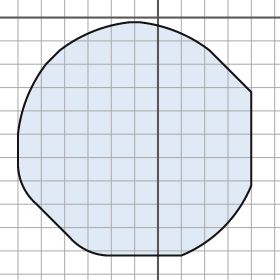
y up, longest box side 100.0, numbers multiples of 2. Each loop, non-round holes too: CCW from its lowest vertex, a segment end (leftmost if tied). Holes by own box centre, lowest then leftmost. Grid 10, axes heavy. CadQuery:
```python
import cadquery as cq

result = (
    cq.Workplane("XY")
    .moveTo(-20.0, -102.0)
    .lineTo(10.0, -102.0)
    .threePointArc((28.0, -90.0), (40.0, -72.0))
    .lineTo(40.0, -32.0)
    .lineTo(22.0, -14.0)
    .threePointArc((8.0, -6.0), (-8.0, -2.0))
    .lineTo(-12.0, -2.0)
    .threePointArc((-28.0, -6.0), (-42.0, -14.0))
    .lineTo(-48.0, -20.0)
    .threePointArc((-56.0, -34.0), (-60.0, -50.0))
    .lineTo(-60.0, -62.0)
    .threePointArc((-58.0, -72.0), (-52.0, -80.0))
    .lineTo(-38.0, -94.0)
    .threePointArc((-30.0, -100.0), (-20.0, -102.0))
    .close()
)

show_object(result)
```